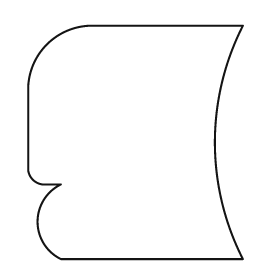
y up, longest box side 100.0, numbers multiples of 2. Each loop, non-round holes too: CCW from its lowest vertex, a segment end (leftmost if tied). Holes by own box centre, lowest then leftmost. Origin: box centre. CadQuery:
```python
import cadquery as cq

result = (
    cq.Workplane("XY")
    .moveTo(-32.0, -50.0)
    .lineTo(46.0, -50.0)
    .threePointArc((34.0, 0.0), (46.0, 50.0))
    .lineTo(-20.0, 50.0)
    .threePointArc((-38.0, 42.0), (-46.0, 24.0))
    .lineTo(-46.0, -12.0)
    .threePointArc((-44.0, -16.0), (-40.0, -18.0))
    .lineTo(-32.0, -18.0)
    .threePointArc((-42.0, -34.0), (-32.0, -50.0))
    .close()
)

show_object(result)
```